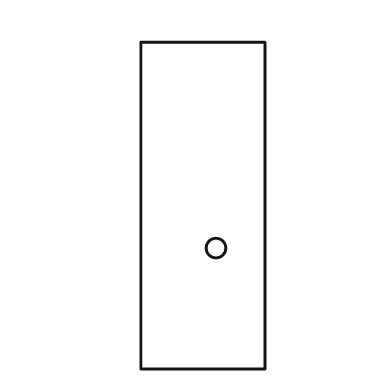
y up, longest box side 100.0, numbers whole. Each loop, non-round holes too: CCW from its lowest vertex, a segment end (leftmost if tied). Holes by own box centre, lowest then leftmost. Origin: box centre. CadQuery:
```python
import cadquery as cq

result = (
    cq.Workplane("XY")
    .moveTo(-19.0, -50.0)
    .lineTo(19.0, -50.0)
    .lineTo(19.0, 50.0)
    .lineTo(-19.0, 50.0)
    .close()
    .moveTo(4.0, -13.0)
    .circle(3.0)
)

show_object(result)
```